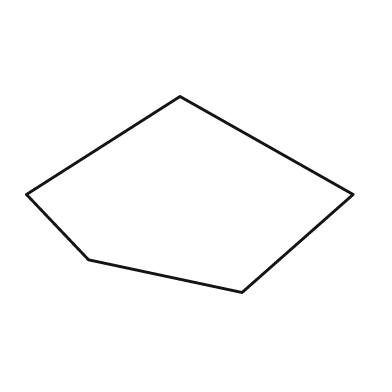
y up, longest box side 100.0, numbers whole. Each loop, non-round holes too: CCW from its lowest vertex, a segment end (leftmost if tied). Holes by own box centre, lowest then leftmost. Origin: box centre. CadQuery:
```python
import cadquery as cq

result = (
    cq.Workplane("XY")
    .moveTo(16.0, -30.0)
    .lineTo(50.0, 0.0)
    .lineTo(-3.0, 30.0)
    .lineTo(-50.0, 0.0)
    .lineTo(-31.0, -20.0)
    .close()
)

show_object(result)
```